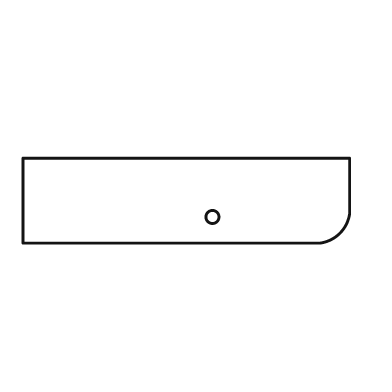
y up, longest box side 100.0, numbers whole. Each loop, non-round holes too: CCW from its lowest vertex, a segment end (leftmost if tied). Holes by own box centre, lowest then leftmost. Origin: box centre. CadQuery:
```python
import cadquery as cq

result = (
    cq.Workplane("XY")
    .moveTo(-50.0, -13.0)
    .lineTo(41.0, -13.0)
    .threePointArc((47.0, -10.0), (50.0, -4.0))
    .lineTo(50.0, 13.0)
    .lineTo(-50.0, 13.0)
    .close()
    .moveTo(8.0, -5.0)
    .circle(2.0)
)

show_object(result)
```